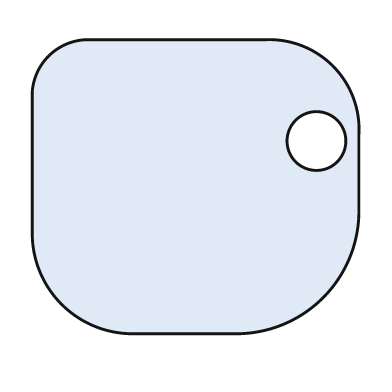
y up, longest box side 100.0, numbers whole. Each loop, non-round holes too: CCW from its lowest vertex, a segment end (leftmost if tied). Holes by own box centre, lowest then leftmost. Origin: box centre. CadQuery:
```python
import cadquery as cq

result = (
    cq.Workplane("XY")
    .moveTo(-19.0, -45.0)
    .lineTo(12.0, -45.0)
    .threePointArc((39.0, -34.0), (50.0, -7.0))
    .lineTo(50.0, 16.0)
    .threePointArc((42.0, 37.0), (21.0, 45.0))
    .lineTo(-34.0, 45.0)
    .threePointArc((-45.0, 40.0), (-50.0, 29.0))
    .lineTo(-50.0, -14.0)
    .threePointArc((-41.0, -36.0), (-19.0, -45.0))
    .close()
    .moveTo(37.0, 14.0)
    .circle(9.0)
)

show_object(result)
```